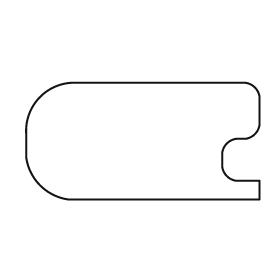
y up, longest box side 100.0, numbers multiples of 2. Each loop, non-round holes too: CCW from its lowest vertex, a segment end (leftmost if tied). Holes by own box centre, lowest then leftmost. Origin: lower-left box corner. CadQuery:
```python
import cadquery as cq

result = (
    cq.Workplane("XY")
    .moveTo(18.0, 0.0)
    .lineTo(100.0, 0.0)
    .lineTo(100.0, 8.0)
    .lineTo(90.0, 8.0)
    .threePointArc((86.0, 10.0), (84.0, 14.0))
    .lineTo(84.0, 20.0)
    .threePointArc((86.0, 24.0), (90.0, 26.0))
    .lineTo(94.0, 26.0)
    .threePointArc((98.0, 28.0), (100.0, 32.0))
    .lineTo(100.0, 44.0)
    .threePointArc((98.0, 48.0), (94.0, 50.0))
    .lineTo(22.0, 50.0)
    .threePointArc((6.0, 44.0), (0.0, 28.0))
    .lineTo(0.0, 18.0)
    .threePointArc((6.0, 6.0), (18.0, 0.0))
    .close()
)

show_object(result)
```